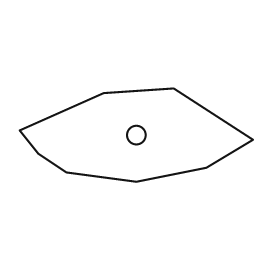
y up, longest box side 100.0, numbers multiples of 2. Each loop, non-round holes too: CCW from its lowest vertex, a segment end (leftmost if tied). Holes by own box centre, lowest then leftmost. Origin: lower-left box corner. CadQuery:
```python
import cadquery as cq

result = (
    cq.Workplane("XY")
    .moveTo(50.0, 0.0)
    .lineTo(80.0, 6.0)
    .lineTo(100.0, 18.0)
    .lineTo(66.0, 40.0)
    .lineTo(36.0, 38.0)
    .lineTo(0.0, 22.0)
    .lineTo(8.0, 12.0)
    .lineTo(20.0, 4.0)
    .close()
    .moveTo(50.0, 20.0)
    .circle(4.0)
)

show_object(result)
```